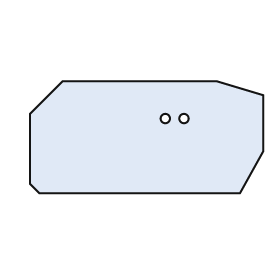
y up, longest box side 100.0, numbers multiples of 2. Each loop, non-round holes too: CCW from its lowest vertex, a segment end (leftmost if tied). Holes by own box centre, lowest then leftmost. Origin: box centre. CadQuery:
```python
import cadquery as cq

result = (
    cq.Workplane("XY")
    .moveTo(-46.0, -24.0)
    .lineTo(40.0, -24.0)
    .lineTo(50.0, -6.0)
    .lineTo(50.0, 18.0)
    .lineTo(30.0, 24.0)
    .lineTo(-36.0, 24.0)
    .lineTo(-50.0, 10.0)
    .lineTo(-50.0, -20.0)
    .close()
    .moveTo(8.0, 8.0)
    .circle(2.0)
    .moveTo(16.0, 8.0)
    .circle(2.0)
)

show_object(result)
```